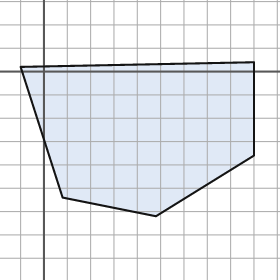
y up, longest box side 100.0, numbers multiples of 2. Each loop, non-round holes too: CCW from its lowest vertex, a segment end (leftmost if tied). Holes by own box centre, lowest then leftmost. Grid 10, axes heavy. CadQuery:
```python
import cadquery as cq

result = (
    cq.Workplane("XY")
    .moveTo(48.0, -62.0)
    .lineTo(90.0, -36.0)
    .lineTo(90.0, 4.0)
    .lineTo(-10.0, 2.0)
    .lineTo(8.0, -54.0)
    .close()
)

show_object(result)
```